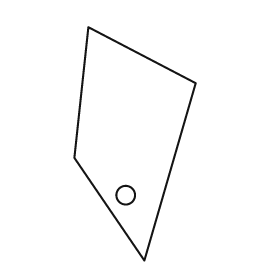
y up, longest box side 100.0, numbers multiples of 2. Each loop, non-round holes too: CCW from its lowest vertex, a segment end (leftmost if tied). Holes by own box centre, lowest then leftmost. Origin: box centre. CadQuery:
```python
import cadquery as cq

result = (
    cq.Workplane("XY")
    .moveTo(4.0, -50.0)
    .lineTo(26.0, 26.0)
    .lineTo(-20.0, 50.0)
    .lineTo(-26.0, -6.0)
    .close()
    .moveTo(-4.0, -22.0)
    .circle(4.0)
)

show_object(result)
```